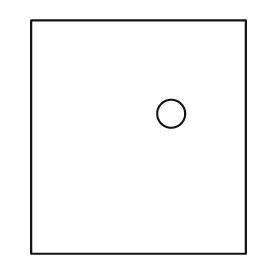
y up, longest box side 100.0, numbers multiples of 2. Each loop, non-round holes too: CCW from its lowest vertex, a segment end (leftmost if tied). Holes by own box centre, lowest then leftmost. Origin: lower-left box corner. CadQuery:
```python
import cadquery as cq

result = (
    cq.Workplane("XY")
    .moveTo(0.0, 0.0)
    .lineTo(92.0, 0.0)
    .lineTo(92.0, 100.0)
    .lineTo(0.0, 100.0)
    .close()
    .moveTo(60.0, 60.0)
    .circle(6.0)
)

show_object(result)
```